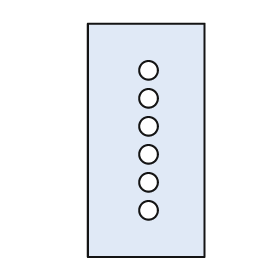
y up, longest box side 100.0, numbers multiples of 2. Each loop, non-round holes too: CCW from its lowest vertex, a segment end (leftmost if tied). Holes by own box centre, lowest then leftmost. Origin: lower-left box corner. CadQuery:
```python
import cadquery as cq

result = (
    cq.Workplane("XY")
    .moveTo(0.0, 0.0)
    .lineTo(50.0, 0.0)
    .lineTo(50.0, 100.0)
    .lineTo(0.0, 100.0)
    .close()
    .moveTo(26.0, 20.0)
    .circle(4.0)
    .moveTo(26.0, 32.0)
    .circle(4.0)
    .moveTo(26.0, 44.0)
    .circle(4.0)
    .moveTo(26.0, 56.0)
    .circle(4.0)
    .moveTo(26.0, 68.0)
    .circle(4.0)
    .moveTo(26.0, 80.0)
    .circle(4.0)
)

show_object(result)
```